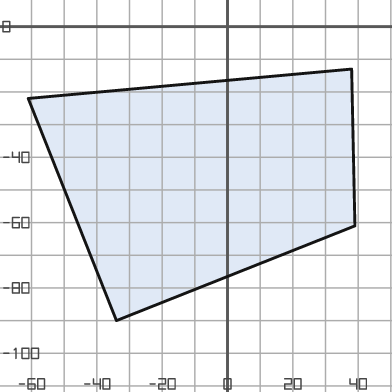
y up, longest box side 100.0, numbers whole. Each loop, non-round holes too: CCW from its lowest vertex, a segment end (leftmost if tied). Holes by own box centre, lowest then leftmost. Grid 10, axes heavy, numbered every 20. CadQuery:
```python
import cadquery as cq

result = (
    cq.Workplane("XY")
    .moveTo(-34.0, -90.0)
    .lineTo(39.0, -61.0)
    .lineTo(38.0, -13.0)
    .lineTo(-61.0, -22.0)
    .close()
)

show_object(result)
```